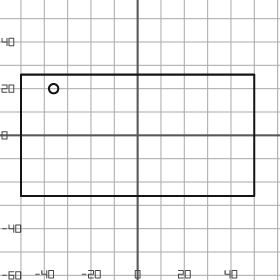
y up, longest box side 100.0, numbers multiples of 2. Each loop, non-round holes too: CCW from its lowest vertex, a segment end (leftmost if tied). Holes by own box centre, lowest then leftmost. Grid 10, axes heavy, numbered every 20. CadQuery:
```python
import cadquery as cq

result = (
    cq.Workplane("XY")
    .moveTo(-50.0, -26.0)
    .lineTo(50.0, -26.0)
    .lineTo(50.0, 26.0)
    .lineTo(-50.0, 26.0)
    .close()
    .moveTo(-36.0, 20.0)
    .circle(2.0)
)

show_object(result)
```